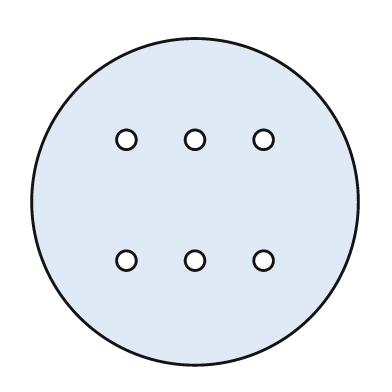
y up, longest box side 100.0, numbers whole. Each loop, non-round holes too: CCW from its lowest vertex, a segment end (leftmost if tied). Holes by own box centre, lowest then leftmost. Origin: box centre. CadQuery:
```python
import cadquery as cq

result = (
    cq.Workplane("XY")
    .moveTo(0.0, 0.0)
    .circle(50.0)
    .moveTo(-21.0, -18.0)
    .circle(3.0)
    .moveTo(0.0, -18.0)
    .circle(3.0)
    .moveTo(21.0, -18.0)
    .circle(3.0)
    .moveTo(-21.0, 19.0)
    .circle(3.0)
    .moveTo(0.0, 19.0)
    .circle(3.0)
    .moveTo(21.0, 19.0)
    .circle(3.0)
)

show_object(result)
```